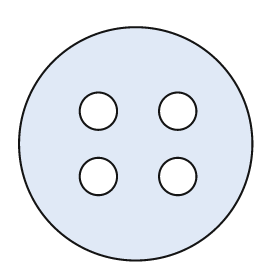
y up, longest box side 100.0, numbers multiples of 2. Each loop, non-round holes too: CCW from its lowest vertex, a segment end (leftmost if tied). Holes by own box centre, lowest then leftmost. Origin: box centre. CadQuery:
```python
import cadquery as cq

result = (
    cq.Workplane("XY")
    .moveTo(0.0, 0.0)
    .circle(50.0)
    .moveTo(-16.0, -14.0)
    .circle(8.0)
    .moveTo(18.0, -14.0)
    .circle(8.0)
    .moveTo(-16.0, 14.0)
    .circle(8.0)
    .moveTo(18.0, 14.0)
    .circle(8.0)
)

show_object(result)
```